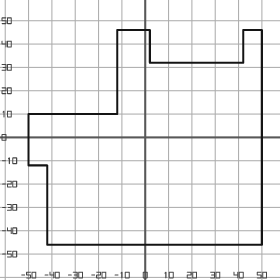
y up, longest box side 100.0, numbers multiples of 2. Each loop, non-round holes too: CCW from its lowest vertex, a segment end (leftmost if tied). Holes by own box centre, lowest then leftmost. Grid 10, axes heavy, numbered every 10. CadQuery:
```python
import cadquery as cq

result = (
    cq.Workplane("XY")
    .moveTo(-42.0, -46.0)
    .lineTo(50.0, -46.0)
    .lineTo(50.0, 46.0)
    .lineTo(42.0, 46.0)
    .lineTo(42.0, 32.0)
    .lineTo(2.0, 32.0)
    .lineTo(2.0, 46.0)
    .lineTo(-12.0, 46.0)
    .lineTo(-12.0, 10.0)
    .lineTo(-50.0, 10.0)
    .lineTo(-50.0, -12.0)
    .lineTo(-42.0, -12.0)
    .close()
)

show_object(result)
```